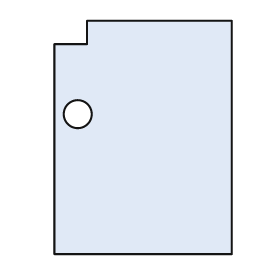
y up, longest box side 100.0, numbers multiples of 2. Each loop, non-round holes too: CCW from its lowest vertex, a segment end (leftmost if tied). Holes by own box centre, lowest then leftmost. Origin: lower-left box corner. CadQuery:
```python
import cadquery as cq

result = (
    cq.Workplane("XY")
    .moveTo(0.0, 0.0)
    .lineTo(76.0, 0.0)
    .lineTo(76.0, 100.0)
    .lineTo(14.0, 100.0)
    .lineTo(14.0, 90.0)
    .lineTo(0.0, 90.0)
    .close()
    .moveTo(10.0, 60.0)
    .circle(6.0)
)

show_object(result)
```